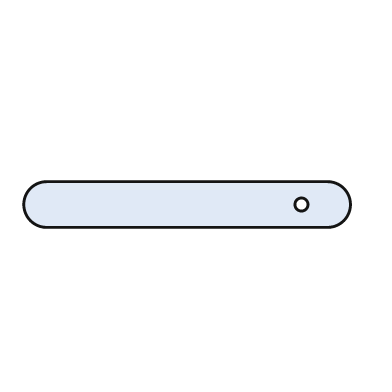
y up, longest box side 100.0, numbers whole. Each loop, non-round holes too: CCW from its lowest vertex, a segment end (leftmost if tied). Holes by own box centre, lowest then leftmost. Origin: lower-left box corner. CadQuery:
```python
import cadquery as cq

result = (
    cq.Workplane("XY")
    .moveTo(7.0, 0.0)
    .lineTo(93.0, 0.0)
    .threePointArc((100.0, 7.0), (93.0, 14.0))
    .lineTo(7.0, 14.0)
    .threePointArc((0.0, 7.0), (7.0, 0.0))
    .close()
    .moveTo(85.0, 7.0)
    .circle(2.0)
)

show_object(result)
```